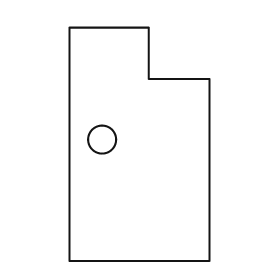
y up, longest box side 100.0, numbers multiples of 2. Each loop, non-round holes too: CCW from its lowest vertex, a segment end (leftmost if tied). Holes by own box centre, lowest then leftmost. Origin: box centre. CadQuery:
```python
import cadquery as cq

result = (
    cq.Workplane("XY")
    .moveTo(-30.0, -50.0)
    .lineTo(30.0, -50.0)
    .lineTo(30.0, 28.0)
    .lineTo(4.0, 28.0)
    .lineTo(4.0, 50.0)
    .lineTo(-30.0, 50.0)
    .close()
    .moveTo(-16.0, 2.0)
    .circle(6.0)
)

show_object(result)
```